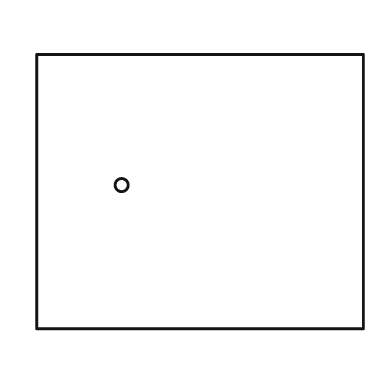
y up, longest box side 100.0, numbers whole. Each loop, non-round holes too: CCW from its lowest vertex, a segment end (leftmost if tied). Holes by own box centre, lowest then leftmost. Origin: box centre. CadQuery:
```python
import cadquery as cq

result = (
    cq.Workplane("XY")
    .moveTo(-50.0, -42.0)
    .lineTo(50.0, -42.0)
    .lineTo(50.0, 42.0)
    .lineTo(-50.0, 42.0)
    .close()
    .moveTo(-24.0, 2.0)
    .circle(2.0)
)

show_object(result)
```